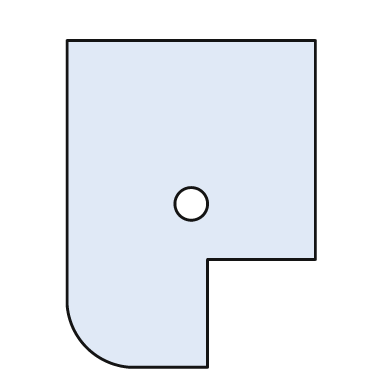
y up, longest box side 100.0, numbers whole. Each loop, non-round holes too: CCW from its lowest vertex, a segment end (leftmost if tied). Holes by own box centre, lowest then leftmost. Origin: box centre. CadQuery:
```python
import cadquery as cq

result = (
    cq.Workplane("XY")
    .moveTo(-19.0, -50.0)
    .lineTo(5.0, -50.0)
    .lineTo(5.0, -17.0)
    .lineTo(38.0, -17.0)
    .lineTo(38.0, 50.0)
    .lineTo(-38.0, 50.0)
    .lineTo(-38.0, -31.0)
    .threePointArc((-32.0, -44.0), (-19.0, -50.0))
    .close()
    .moveTo(0.0, 0.0)
    .circle(5.0)
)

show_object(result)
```